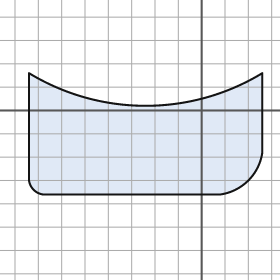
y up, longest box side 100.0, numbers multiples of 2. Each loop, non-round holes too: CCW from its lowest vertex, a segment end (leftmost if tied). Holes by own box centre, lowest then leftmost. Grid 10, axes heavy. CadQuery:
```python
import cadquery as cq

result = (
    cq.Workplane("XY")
    .moveTo(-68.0, -36.0)
    .lineTo(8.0, -36.0)
    .threePointArc((20.0, -30.0), (26.0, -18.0))
    .lineTo(26.0, 16.0)
    .threePointArc((-24.0, 2.0), (-74.0, 16.0))
    .lineTo(-74.0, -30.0)
    .threePointArc((-72.0, -34.0), (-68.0, -36.0))
    .close()
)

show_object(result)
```